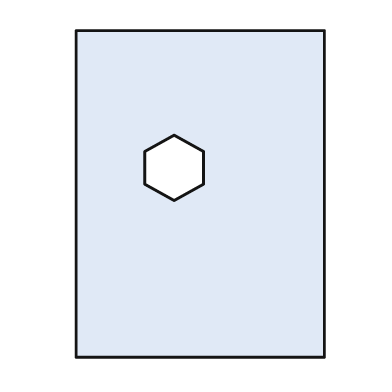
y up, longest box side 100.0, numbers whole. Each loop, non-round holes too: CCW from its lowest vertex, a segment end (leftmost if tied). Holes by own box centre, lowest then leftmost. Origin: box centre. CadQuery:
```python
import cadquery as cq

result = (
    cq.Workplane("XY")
    .moveTo(-38.0, -50.0)
    .lineTo(38.0, -50.0)
    .lineTo(38.0, 50.0)
    .lineTo(-38.0, 50.0)
    .close()
    .moveTo(-8.0, -2.0)
    .lineTo(1.0, 3.0)
    .lineTo(1.0, 13.0)
    .lineTo(-8.0, 18.0)
    .lineTo(-17.0, 13.0)
    .lineTo(-17.0, 3.0)
    .close()
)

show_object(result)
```